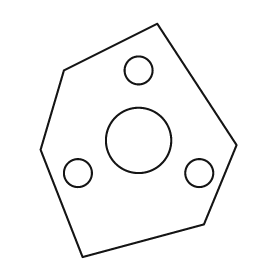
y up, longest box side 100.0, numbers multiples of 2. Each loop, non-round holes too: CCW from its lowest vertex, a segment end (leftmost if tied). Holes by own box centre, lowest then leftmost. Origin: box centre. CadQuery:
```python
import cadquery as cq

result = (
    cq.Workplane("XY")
    .moveTo(-24.0, -50.0)
    .lineTo(28.0, -36.0)
    .lineTo(42.0, -2.0)
    .lineTo(8.0, 50.0)
    .lineTo(-32.0, 30.0)
    .lineTo(-42.0, -4.0)
    .close()
    .moveTo(-26.0, -14.0)
    .circle(6.0)
    .moveTo(26.0, -14.0)
    .circle(6.0)
    .moveTo(0.0, 0.0)
    .circle(14.0)
    .moveTo(0.0, 30.0)
    .circle(6.0)
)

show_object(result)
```